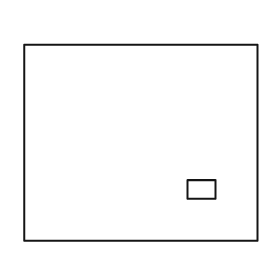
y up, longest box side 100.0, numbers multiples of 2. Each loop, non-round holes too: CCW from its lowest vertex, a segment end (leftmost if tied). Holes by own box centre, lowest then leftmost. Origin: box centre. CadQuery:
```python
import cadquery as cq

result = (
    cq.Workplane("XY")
    .moveTo(-50.0, -42.0)
    .lineTo(50.0, -42.0)
    .lineTo(50.0, 42.0)
    .lineTo(-50.0, 42.0)
    .close()
    .moveTo(20.0, -24.0)
    .lineTo(32.0, -24.0)
    .lineTo(32.0, -16.0)
    .lineTo(20.0, -16.0)
    .close()
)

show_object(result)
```